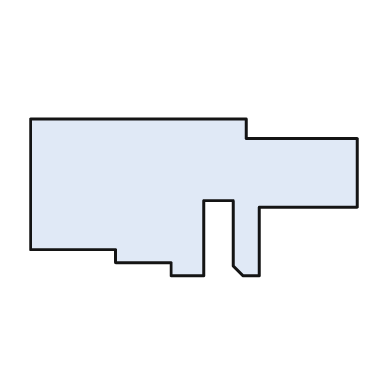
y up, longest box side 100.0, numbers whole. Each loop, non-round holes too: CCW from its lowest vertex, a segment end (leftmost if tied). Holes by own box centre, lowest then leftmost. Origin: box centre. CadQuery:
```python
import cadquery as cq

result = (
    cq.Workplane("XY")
    .moveTo(-7.0, -24.0)
    .lineTo(3.0, -24.0)
    .lineTo(3.0, -1.0)
    .lineTo(12.0, -1.0)
    .lineTo(12.0, -21.0)
    .lineTo(15.0, -24.0)
    .lineTo(20.0, -24.0)
    .lineTo(20.0, -3.0)
    .lineTo(50.0, -3.0)
    .lineTo(50.0, 18.0)
    .lineTo(16.0, 18.0)
    .lineTo(16.0, 24.0)
    .lineTo(-50.0, 24.0)
    .lineTo(-50.0, -16.0)
    .lineTo(-24.0, -16.0)
    .lineTo(-24.0, -20.0)
    .lineTo(-7.0, -20.0)
    .close()
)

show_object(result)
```